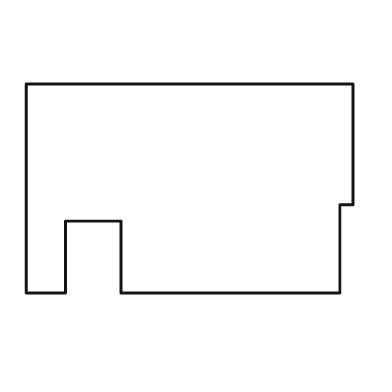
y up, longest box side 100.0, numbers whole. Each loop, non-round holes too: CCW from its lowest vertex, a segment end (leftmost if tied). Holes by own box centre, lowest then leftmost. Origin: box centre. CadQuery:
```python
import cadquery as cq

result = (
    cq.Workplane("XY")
    .moveTo(-50.0, -32.0)
    .lineTo(-38.0, -32.0)
    .lineTo(-38.0, -10.0)
    .lineTo(-21.0, -10.0)
    .lineTo(-21.0, -32.0)
    .lineTo(46.0, -32.0)
    .lineTo(46.0, -5.0)
    .lineTo(50.0, -5.0)
    .lineTo(50.0, 32.0)
    .lineTo(-50.0, 32.0)
    .close()
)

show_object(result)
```